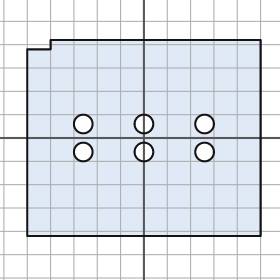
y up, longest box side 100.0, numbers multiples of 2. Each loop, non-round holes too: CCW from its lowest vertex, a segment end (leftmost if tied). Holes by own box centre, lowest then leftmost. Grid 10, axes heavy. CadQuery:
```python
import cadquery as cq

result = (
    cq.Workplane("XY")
    .moveTo(-50.0, -42.0)
    .lineTo(50.0, -42.0)
    .lineTo(50.0, 42.0)
    .lineTo(-40.0, 42.0)
    .lineTo(-40.0, 38.0)
    .lineTo(-50.0, 38.0)
    .close()
    .moveTo(-26.0, -6.0)
    .circle(4.0)
    .moveTo(0.0, -6.0)
    .circle(4.0)
    .moveTo(26.0, -6.0)
    .circle(4.0)
    .moveTo(-26.0, 6.0)
    .circle(4.0)
    .moveTo(0.0, 6.0)
    .circle(4.0)
    .moveTo(26.0, 6.0)
    .circle(4.0)
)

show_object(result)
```